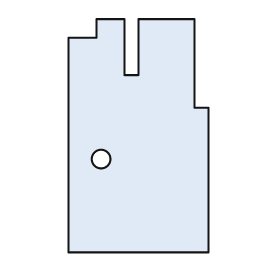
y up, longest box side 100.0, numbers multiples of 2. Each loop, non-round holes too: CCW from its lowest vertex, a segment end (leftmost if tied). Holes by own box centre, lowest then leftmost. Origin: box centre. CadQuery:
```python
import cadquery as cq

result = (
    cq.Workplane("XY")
    .moveTo(-30.0, -50.0)
    .lineTo(30.0, -50.0)
    .lineTo(30.0, 12.0)
    .lineTo(24.0, 12.0)
    .lineTo(24.0, 50.0)
    .lineTo(0.0, 50.0)
    .lineTo(0.0, 26.0)
    .lineTo(-6.0, 26.0)
    .lineTo(-6.0, 50.0)
    .lineTo(-18.0, 50.0)
    .lineTo(-18.0, 42.0)
    .lineTo(-30.0, 42.0)
    .close()
    .moveTo(-16.0, -10.0)
    .circle(4.0)
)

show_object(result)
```